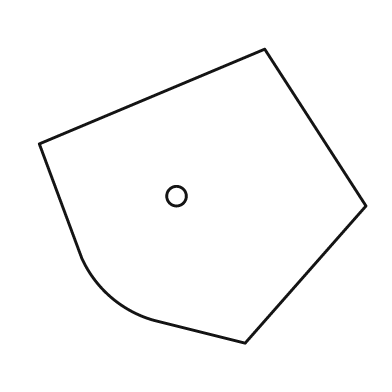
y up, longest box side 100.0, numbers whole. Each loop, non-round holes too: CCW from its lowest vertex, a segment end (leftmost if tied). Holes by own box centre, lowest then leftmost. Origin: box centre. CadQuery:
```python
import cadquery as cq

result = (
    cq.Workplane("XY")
    .moveTo(13.0, -45.0)
    .lineTo(50.0, -3.0)
    .lineTo(19.0, 45.0)
    .lineTo(-50.0, 16.0)
    .lineTo(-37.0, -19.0)
    .threePointArc((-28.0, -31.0), (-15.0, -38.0))
    .close()
    .moveTo(-8.0, 0.0)
    .circle(3.0)
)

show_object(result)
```